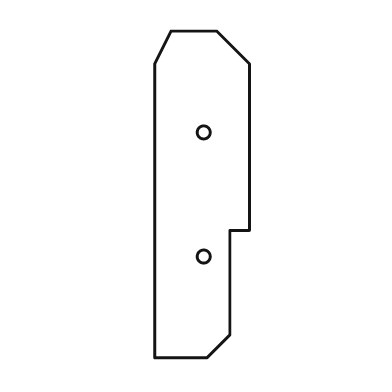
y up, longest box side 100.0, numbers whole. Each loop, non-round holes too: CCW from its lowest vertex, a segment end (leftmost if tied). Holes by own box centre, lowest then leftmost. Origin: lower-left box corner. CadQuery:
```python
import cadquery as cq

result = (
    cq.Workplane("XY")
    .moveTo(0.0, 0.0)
    .lineTo(16.0, 0.0)
    .lineTo(23.0, 7.0)
    .lineTo(23.0, 39.0)
    .lineTo(29.0, 39.0)
    .lineTo(29.0, 90.0)
    .lineTo(19.0, 100.0)
    .lineTo(5.0, 100.0)
    .lineTo(0.0, 90.0)
    .close()
    .moveTo(15.0, 31.0)
    .circle(2.0)
    .moveTo(15.0, 69.0)
    .circle(2.0)
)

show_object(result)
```